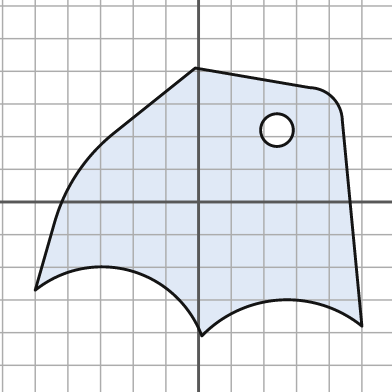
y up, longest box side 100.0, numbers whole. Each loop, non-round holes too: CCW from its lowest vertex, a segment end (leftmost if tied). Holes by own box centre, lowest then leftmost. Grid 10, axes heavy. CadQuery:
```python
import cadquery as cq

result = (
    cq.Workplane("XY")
    .moveTo(1.0, -41.0)
    .threePointArc((25.0, -30.0), (50.0, -38.0))
    .lineTo(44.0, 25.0)
    .threePointArc((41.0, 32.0), (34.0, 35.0))
    .lineTo(-1.0, 41.0)
    .lineTo(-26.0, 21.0)
    .threePointArc((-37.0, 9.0), (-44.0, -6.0))
    .lineTo(-50.0, -27.0)
    .threePointArc((-21.0, -21.0), (1.0, -41.0))
    .close()
    .moveTo(24.0, 22.0)
    .circle(5.0)
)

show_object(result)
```